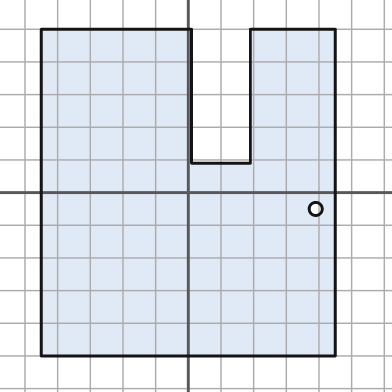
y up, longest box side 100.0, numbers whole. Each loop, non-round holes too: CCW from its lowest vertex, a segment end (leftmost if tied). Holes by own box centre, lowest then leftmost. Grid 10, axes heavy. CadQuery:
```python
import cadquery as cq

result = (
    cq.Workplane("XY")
    .moveTo(-45.0, -50.0)
    .lineTo(45.0, -50.0)
    .lineTo(45.0, 50.0)
    .lineTo(19.0, 50.0)
    .lineTo(19.0, 9.0)
    .lineTo(1.0, 9.0)
    .lineTo(1.0, 50.0)
    .lineTo(-45.0, 50.0)
    .close()
    .moveTo(39.0, -5.0)
    .circle(2.0)
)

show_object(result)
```